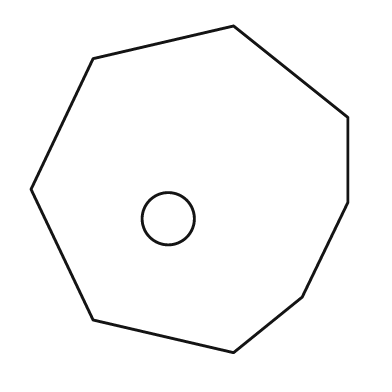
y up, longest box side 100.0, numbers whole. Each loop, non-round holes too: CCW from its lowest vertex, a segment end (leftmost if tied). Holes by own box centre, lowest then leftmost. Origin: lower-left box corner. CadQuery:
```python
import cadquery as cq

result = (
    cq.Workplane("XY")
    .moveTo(62.0, 0.0)
    .lineTo(83.0, 17.0)
    .lineTo(97.0, 46.0)
    .lineTo(97.0, 72.0)
    .lineTo(62.0, 100.0)
    .lineTo(19.0, 90.0)
    .lineTo(0.0, 50.0)
    .lineTo(19.0, 10.0)
    .close()
    .moveTo(42.0, 41.0)
    .circle(8.0)
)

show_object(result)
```